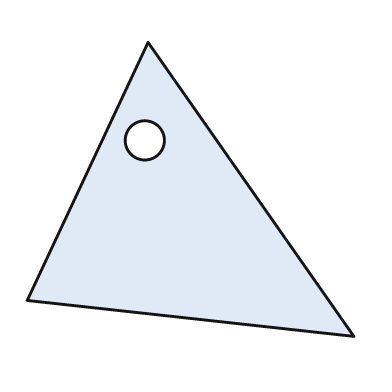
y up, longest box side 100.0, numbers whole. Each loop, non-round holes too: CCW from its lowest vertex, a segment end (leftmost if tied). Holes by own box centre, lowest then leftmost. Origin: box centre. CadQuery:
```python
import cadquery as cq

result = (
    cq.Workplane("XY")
    .moveTo(50.0, -45.0)
    .lineTo(-13.0, 45.0)
    .lineTo(-50.0, -34.0)
    .close()
    .moveTo(-14.0, 15.0)
    .circle(6.0)
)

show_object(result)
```